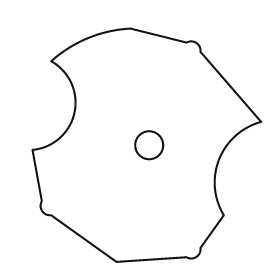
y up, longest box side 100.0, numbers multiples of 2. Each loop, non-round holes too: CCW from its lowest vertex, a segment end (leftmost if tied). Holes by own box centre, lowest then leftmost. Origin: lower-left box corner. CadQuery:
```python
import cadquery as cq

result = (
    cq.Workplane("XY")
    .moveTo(36.0, 0.0)
    .lineTo(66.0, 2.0)
    .threePointArc((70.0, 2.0), (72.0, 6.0))
    .lineTo(82.0, 20.0)
    .threePointArc((80.0, 44.0), (98.0, 60.0))
    .lineTo(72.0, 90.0)
    .threePointArc((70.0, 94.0), (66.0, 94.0))
    .lineTo(42.0, 100.0)
    .threePointArc((24.0, 96.0), (8.0, 86.0))
    .threePointArc((18.0, 64.0), (0.0, 48.0))
    .lineTo(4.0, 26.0)
    .threePointArc((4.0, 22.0), (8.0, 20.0))
    .close()
    .moveTo(50.0, 50.0)
    .circle(6.0)
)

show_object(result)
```